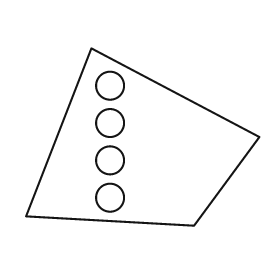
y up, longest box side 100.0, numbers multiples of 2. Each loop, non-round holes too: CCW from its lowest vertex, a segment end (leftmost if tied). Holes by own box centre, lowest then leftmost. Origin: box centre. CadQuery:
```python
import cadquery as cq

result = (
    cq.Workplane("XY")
    .moveTo(22.0, -38.0)
    .lineTo(50.0, 0.0)
    .lineTo(-22.0, 38.0)
    .lineTo(-50.0, -34.0)
    .close()
    .moveTo(-14.0, -26.0)
    .circle(6.0)
    .moveTo(-14.0, -10.0)
    .circle(6.0)
    .moveTo(-14.0, 6.0)
    .circle(6.0)
    .moveTo(-14.0, 22.0)
    .circle(6.0)
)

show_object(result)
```